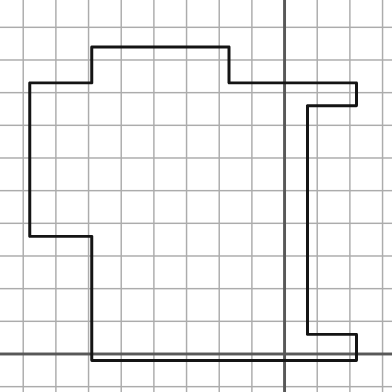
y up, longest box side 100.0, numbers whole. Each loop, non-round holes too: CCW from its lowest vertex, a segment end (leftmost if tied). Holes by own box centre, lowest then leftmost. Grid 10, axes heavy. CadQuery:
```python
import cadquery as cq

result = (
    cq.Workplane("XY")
    .moveTo(-59.0, -2.0)
    .lineTo(22.0, -2.0)
    .lineTo(22.0, 6.0)
    .lineTo(7.0, 6.0)
    .lineTo(7.0, 76.0)
    .lineTo(22.0, 76.0)
    .lineTo(22.0, 83.0)
    .lineTo(-17.0, 83.0)
    .lineTo(-17.0, 94.0)
    .lineTo(-59.0, 94.0)
    .lineTo(-59.0, 83.0)
    .lineTo(-78.0, 83.0)
    .lineTo(-78.0, 36.0)
    .lineTo(-59.0, 36.0)
    .close()
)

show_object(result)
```